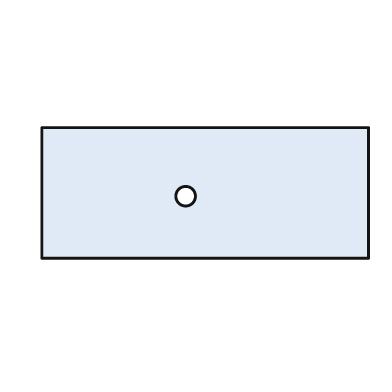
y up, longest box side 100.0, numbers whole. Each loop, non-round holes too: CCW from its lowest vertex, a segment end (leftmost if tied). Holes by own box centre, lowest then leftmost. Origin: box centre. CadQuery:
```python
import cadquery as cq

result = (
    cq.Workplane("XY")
    .moveTo(-50.0, -20.0)
    .lineTo(50.0, -20.0)
    .lineTo(50.0, 20.0)
    .lineTo(-50.0, 20.0)
    .close()
    .moveTo(-6.0, -1.0)
    .circle(3.0)
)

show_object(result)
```